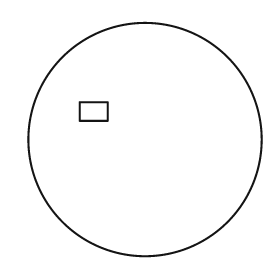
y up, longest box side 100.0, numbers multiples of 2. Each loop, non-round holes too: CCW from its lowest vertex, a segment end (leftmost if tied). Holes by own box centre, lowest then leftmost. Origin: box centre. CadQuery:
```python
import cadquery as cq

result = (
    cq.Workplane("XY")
    .moveTo(0.0, 0.0)
    .circle(50.0)
    .moveTo(-28.0, 8.0)
    .lineTo(-16.0, 8.0)
    .lineTo(-16.0, 16.0)
    .lineTo(-28.0, 16.0)
    .close()
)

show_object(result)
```